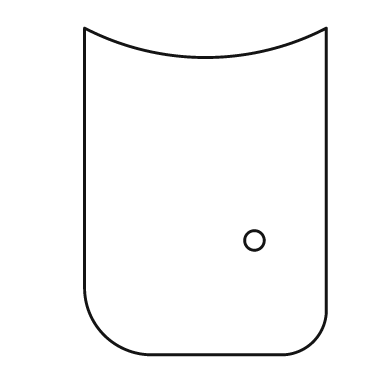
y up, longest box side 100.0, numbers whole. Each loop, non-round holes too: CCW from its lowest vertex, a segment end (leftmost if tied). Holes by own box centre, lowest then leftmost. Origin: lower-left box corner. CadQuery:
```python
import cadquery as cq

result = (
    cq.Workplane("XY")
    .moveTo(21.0, 0.0)
    .lineTo(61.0, 0.0)
    .threePointArc((70.0, 4.0), (74.0, 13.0))
    .lineTo(74.0, 100.0)
    .threePointArc((37.0, 91.0), (0.0, 100.0))
    .lineTo(0.0, 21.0)
    .threePointArc((6.0, 6.0), (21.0, 0.0))
    .close()
    .moveTo(52.0, 35.0)
    .circle(3.0)
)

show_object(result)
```